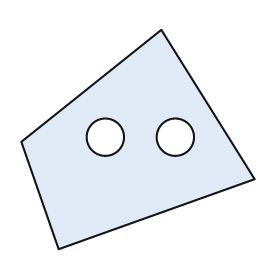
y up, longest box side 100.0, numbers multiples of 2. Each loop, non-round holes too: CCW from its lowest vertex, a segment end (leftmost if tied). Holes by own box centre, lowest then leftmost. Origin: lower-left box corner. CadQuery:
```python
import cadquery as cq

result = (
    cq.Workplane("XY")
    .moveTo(16.0, 0.0)
    .lineTo(100.0, 30.0)
    .lineTo(60.0, 94.0)
    .lineTo(0.0, 46.0)
    .close()
    .moveTo(36.0, 48.0)
    .circle(8.0)
    .moveTo(66.0, 48.0)
    .circle(8.0)
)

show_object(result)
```